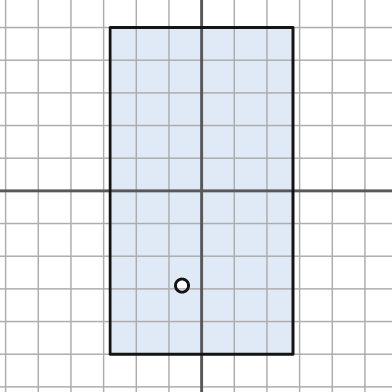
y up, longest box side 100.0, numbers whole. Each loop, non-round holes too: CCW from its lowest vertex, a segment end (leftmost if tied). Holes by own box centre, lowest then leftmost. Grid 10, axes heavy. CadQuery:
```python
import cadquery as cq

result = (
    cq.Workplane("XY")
    .moveTo(-28.0, -50.0)
    .lineTo(28.0, -50.0)
    .lineTo(28.0, 50.0)
    .lineTo(-28.0, 50.0)
    .close()
    .moveTo(-6.0, -29.0)
    .circle(2.0)
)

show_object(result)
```